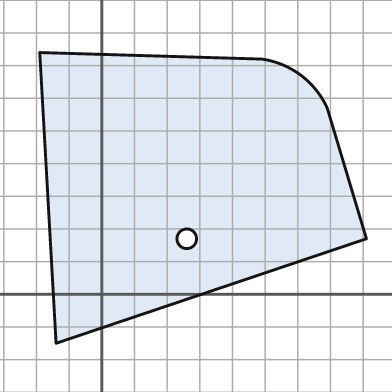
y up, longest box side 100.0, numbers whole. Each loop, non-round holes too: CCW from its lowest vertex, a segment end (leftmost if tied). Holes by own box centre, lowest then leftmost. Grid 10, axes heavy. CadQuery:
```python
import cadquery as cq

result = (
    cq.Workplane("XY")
    .moveTo(-14.0, -15.0)
    .lineTo(81.0, 17.0)
    .lineTo(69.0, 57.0)
    .threePointArc((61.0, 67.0), (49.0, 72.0))
    .lineTo(-19.0, 74.0)
    .close()
    .moveTo(26.0, 17.0)
    .circle(3.0)
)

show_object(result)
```